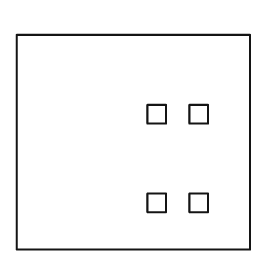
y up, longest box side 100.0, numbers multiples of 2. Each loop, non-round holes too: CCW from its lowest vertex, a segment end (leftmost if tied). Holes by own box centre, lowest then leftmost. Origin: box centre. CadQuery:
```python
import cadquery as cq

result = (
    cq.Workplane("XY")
    .moveTo(-50.0, -46.0)
    .lineTo(50.0, -46.0)
    .lineTo(50.0, 46.0)
    .lineTo(-50.0, 46.0)
    .close()
    .moveTo(6.0, -30.0)
    .lineTo(14.0, -30.0)
    .lineTo(14.0, -22.0)
    .lineTo(6.0, -22.0)
    .close()
    .moveTo(24.0, -30.0)
    .lineTo(32.0, -30.0)
    .lineTo(32.0, -22.0)
    .lineTo(24.0, -22.0)
    .close()
    .moveTo(6.0, 8.0)
    .lineTo(14.0, 8.0)
    .lineTo(14.0, 16.0)
    .lineTo(6.0, 16.0)
    .close()
    .moveTo(24.0, 8.0)
    .lineTo(32.0, 8.0)
    .lineTo(32.0, 16.0)
    .lineTo(24.0, 16.0)
    .close()
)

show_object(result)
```